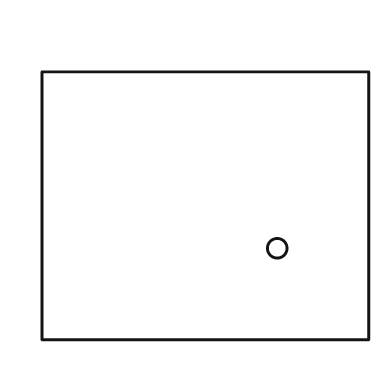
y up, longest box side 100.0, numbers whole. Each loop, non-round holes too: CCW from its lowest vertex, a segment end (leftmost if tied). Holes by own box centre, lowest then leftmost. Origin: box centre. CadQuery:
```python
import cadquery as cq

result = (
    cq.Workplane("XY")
    .moveTo(-50.0, -41.0)
    .lineTo(50.0, -41.0)
    .lineTo(50.0, 41.0)
    .lineTo(-50.0, 41.0)
    .close()
    .moveTo(22.0, -13.0)
    .circle(3.0)
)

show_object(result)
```